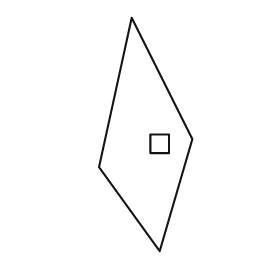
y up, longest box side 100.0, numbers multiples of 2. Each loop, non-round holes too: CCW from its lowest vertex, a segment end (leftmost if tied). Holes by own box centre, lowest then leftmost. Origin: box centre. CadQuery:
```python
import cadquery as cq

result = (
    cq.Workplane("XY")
    .moveTo(6.0, -50.0)
    .lineTo(20.0, -2.0)
    .lineTo(-6.0, 50.0)
    .lineTo(-20.0, -14.0)
    .close()
    .moveTo(2.0, -8.0)
    .lineTo(10.0, -8.0)
    .lineTo(10.0, 0.0)
    .lineTo(2.0, 0.0)
    .close()
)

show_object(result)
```